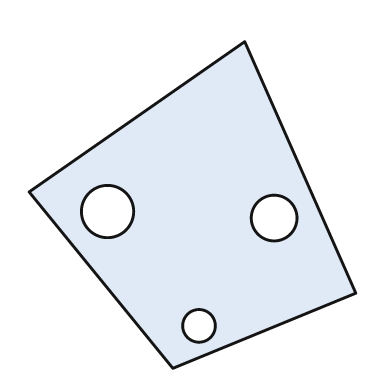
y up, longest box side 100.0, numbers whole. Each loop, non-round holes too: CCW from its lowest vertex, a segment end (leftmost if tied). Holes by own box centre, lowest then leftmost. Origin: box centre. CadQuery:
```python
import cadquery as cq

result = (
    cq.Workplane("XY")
    .moveTo(-6.0, -50.0)
    .lineTo(50.0, -27.0)
    .lineTo(16.0, 50.0)
    .lineTo(-50.0, 4.0)
    .close()
    .moveTo(2.0, -37.0)
    .circle(5.0)
    .moveTo(25.0, -4.0)
    .circle(7.0)
    .moveTo(-26.0, -2.0)
    .circle(8.0)
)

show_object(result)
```